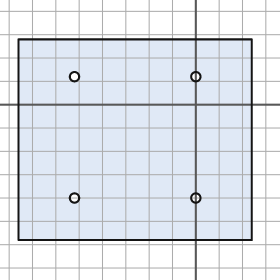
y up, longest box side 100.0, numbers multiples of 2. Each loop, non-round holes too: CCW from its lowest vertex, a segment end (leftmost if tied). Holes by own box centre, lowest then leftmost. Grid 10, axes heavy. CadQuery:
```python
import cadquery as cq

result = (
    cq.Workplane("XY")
    .moveTo(-76.0, -58.0)
    .lineTo(24.0, -58.0)
    .lineTo(24.0, 28.0)
    .lineTo(-76.0, 28.0)
    .close()
    .moveTo(-52.0, -40.0)
    .circle(2.0)
    .moveTo(0.0, -40.0)
    .circle(2.0)
    .moveTo(-52.0, 12.0)
    .circle(2.0)
    .moveTo(0.0, 12.0)
    .circle(2.0)
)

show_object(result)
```